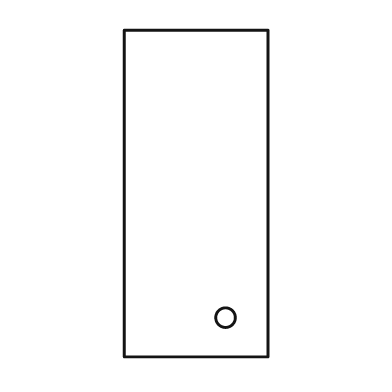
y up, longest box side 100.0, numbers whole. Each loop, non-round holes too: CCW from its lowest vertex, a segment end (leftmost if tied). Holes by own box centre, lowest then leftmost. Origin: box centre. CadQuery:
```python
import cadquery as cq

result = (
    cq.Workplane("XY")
    .moveTo(-22.0, -50.0)
    .lineTo(22.0, -50.0)
    .lineTo(22.0, 50.0)
    .lineTo(-22.0, 50.0)
    .close()
    .moveTo(9.0, -38.0)
    .circle(3.0)
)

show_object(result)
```